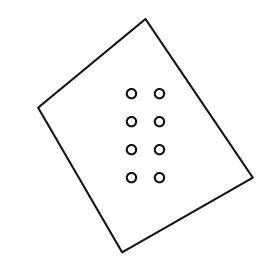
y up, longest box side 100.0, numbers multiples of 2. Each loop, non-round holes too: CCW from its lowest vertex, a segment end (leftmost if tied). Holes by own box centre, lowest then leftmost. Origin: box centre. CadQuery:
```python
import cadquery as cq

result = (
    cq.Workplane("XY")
    .moveTo(-10.0, -50.0)
    .lineTo(46.0, -18.0)
    .lineTo(0.0, 50.0)
    .lineTo(-46.0, 12.0)
    .close()
    .moveTo(-6.0, -18.0)
    .circle(2.0)
    .moveTo(6.0, -18.0)
    .circle(2.0)
    .moveTo(-6.0, -6.0)
    .circle(2.0)
    .moveTo(6.0, -6.0)
    .circle(2.0)
    .moveTo(-6.0, 6.0)
    .circle(2.0)
    .moveTo(6.0, 6.0)
    .circle(2.0)
    .moveTo(-6.0, 18.0)
    .circle(2.0)
    .moveTo(6.0, 18.0)
    .circle(2.0)
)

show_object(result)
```